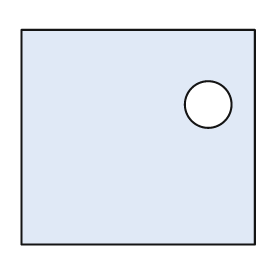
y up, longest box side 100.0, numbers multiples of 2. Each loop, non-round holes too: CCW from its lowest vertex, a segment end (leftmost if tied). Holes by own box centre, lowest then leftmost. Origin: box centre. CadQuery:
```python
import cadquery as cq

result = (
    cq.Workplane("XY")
    .moveTo(-50.0, -46.0)
    .lineTo(50.0, -46.0)
    .lineTo(50.0, 46.0)
    .lineTo(-50.0, 46.0)
    .close()
    .moveTo(30.0, 14.0)
    .circle(10.0)
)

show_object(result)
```